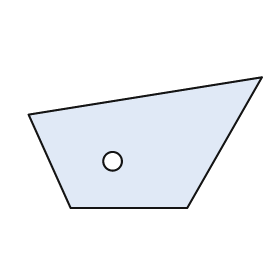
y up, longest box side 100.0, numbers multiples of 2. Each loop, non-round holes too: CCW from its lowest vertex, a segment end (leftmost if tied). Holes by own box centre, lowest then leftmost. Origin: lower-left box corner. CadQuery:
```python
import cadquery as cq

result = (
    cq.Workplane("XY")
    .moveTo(18.0, 0.0)
    .lineTo(68.0, 0.0)
    .lineTo(100.0, 56.0)
    .lineTo(0.0, 40.0)
    .close()
    .moveTo(36.0, 20.0)
    .circle(4.0)
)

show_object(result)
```